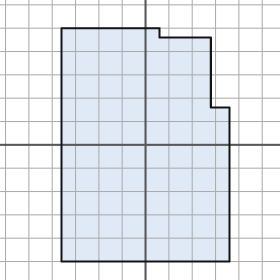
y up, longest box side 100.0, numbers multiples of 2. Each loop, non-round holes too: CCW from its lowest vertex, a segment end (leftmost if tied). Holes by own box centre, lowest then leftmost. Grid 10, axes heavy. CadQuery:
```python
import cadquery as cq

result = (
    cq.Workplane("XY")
    .moveTo(-36.0, -50.0)
    .lineTo(36.0, -50.0)
    .lineTo(36.0, 16.0)
    .lineTo(28.0, 16.0)
    .lineTo(28.0, 46.0)
    .lineTo(6.0, 46.0)
    .lineTo(6.0, 50.0)
    .lineTo(-36.0, 50.0)
    .close()
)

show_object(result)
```